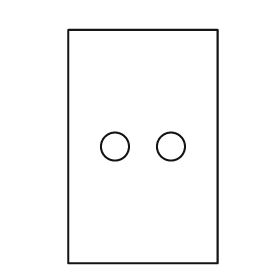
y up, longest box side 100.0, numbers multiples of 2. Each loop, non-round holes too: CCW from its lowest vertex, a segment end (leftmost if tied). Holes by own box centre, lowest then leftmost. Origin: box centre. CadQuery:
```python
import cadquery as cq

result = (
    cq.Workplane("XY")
    .moveTo(-32.0, -50.0)
    .lineTo(32.0, -50.0)
    .lineTo(32.0, 50.0)
    .lineTo(-32.0, 50.0)
    .close()
    .moveTo(-12.0, 0.0)
    .circle(6.0)
    .moveTo(12.0, 0.0)
    .circle(6.0)
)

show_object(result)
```